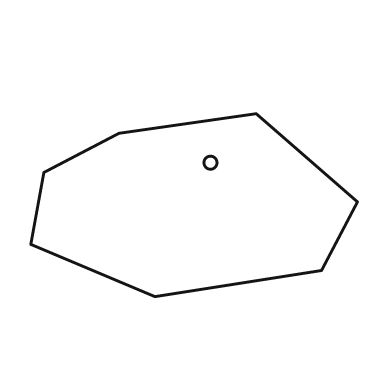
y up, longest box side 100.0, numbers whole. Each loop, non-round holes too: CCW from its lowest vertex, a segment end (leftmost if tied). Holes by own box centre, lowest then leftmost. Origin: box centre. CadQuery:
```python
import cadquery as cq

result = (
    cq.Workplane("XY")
    .moveTo(-12.0, -28.0)
    .lineTo(39.0, -20.0)
    .lineTo(50.0, 1.0)
    .lineTo(19.0, 28.0)
    .lineTo(-23.0, 22.0)
    .lineTo(-46.0, 10.0)
    .lineTo(-50.0, -12.0)
    .close()
    .moveTo(5.0, 13.0)
    .circle(2.0)
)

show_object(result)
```